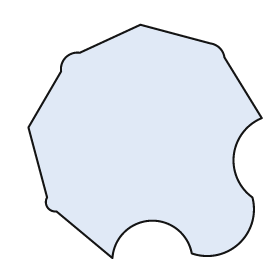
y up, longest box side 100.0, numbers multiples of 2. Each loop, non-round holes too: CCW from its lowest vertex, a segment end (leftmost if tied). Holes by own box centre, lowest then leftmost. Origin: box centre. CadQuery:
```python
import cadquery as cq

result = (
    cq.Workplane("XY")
    .moveTo(-14.0, -50.0)
    .threePointArc((2.0, -34.0), (20.0, -48.0))
    .threePointArc((40.0, -44.0), (46.0, -24.0))
    .threePointArc((38.0, -6.0), (50.0, 10.0))
    .lineTo(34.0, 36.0)
    .threePointArc((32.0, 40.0), (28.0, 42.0))
    .lineTo(-2.0, 50.0)
    .lineTo(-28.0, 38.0)
    .threePointArc((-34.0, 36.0), (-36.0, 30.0))
    .lineTo(-50.0, 6.0)
    .lineTo(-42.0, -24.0)
    .threePointArc((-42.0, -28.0), (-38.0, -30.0))
    .close()
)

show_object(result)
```